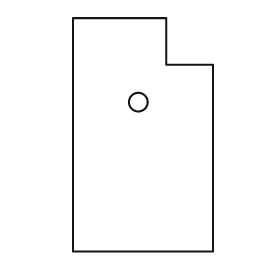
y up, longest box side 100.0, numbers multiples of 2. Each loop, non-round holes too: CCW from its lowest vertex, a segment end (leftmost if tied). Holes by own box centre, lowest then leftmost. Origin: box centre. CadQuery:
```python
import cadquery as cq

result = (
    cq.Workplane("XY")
    .moveTo(-30.0, -50.0)
    .lineTo(30.0, -50.0)
    .lineTo(30.0, 30.0)
    .lineTo(10.0, 30.0)
    .lineTo(10.0, 50.0)
    .lineTo(-30.0, 50.0)
    .close()
    .moveTo(-2.0, 14.0)
    .circle(4.0)
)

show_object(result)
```